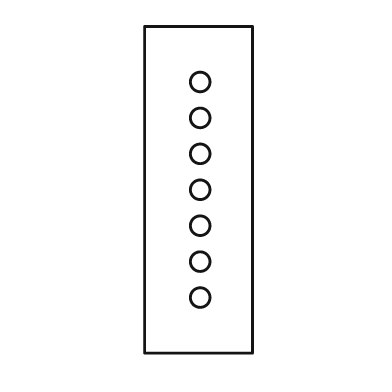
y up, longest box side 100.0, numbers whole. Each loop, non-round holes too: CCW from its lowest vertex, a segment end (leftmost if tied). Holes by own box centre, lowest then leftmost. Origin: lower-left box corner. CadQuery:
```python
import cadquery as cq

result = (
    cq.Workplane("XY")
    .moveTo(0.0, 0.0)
    .lineTo(33.0, 0.0)
    .lineTo(33.0, 100.0)
    .lineTo(0.0, 100.0)
    .close()
    .moveTo(17.0, 17.0)
    .circle(3.0)
    .moveTo(17.0, 28.0)
    .circle(3.0)
    .moveTo(17.0, 39.0)
    .circle(3.0)
    .moveTo(17.0, 50.0)
    .circle(3.0)
    .moveTo(17.0, 61.0)
    .circle(3.0)
    .moveTo(17.0, 72.0)
    .circle(3.0)
    .moveTo(17.0, 83.0)
    .circle(3.0)
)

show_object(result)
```